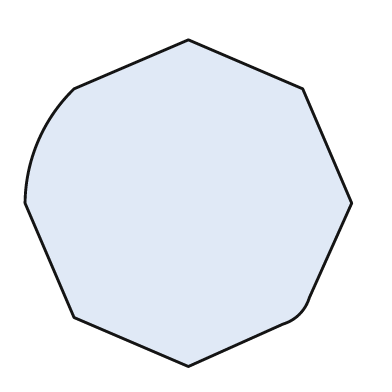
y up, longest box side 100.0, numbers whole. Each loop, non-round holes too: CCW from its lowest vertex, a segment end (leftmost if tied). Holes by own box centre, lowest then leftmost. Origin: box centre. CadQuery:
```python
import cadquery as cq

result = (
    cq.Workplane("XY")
    .moveTo(0.0, -50.0)
    .lineTo(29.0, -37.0)
    .threePointArc((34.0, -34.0), (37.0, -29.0))
    .lineTo(50.0, 0.0)
    .lineTo(35.0, 35.0)
    .lineTo(0.0, 50.0)
    .lineTo(-35.0, 35.0)
    .threePointArc((-46.0, 19.0), (-50.0, 0.0))
    .lineTo(-35.0, -35.0)
    .close()
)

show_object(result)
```